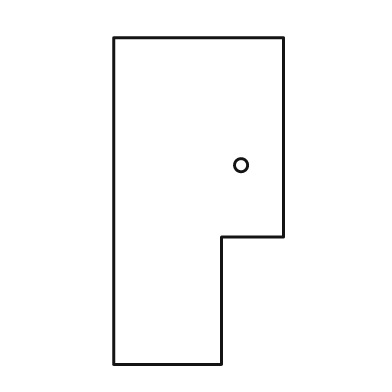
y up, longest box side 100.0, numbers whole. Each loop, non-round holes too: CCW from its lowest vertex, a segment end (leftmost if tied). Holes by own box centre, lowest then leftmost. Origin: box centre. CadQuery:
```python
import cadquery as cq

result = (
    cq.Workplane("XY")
    .moveTo(-26.0, -50.0)
    .lineTo(7.0, -50.0)
    .lineTo(7.0, -11.0)
    .lineTo(26.0, -11.0)
    .lineTo(26.0, 50.0)
    .lineTo(-26.0, 50.0)
    .close()
    .moveTo(13.0, 11.0)
    .circle(2.0)
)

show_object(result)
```